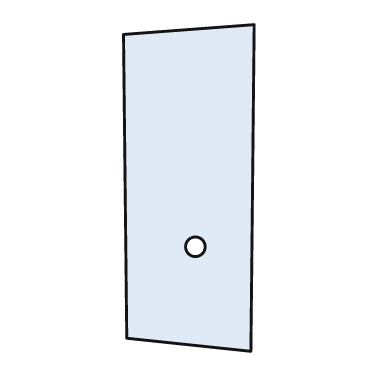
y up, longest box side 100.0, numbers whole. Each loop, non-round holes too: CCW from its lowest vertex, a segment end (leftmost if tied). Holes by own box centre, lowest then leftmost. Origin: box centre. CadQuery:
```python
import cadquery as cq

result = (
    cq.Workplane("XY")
    .moveTo(19.0, -50.0)
    .lineTo(20.0, 50.0)
    .lineTo(-20.0, 47.0)
    .lineTo(-19.0, -46.0)
    .close()
    .moveTo(2.0, -18.0)
    .circle(3.0)
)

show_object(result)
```